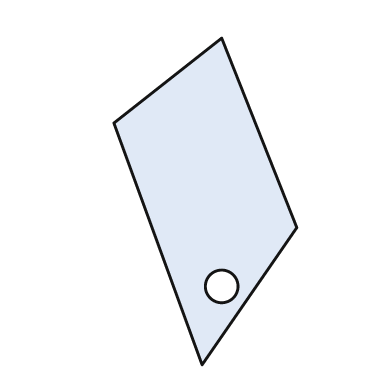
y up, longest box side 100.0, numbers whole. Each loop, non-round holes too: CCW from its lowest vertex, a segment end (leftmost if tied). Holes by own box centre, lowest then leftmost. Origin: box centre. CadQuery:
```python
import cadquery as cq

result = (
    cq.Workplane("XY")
    .moveTo(-1.0, -50.0)
    .lineTo(28.0, -8.0)
    .lineTo(5.0, 50.0)
    .lineTo(-28.0, 24.0)
    .close()
    .moveTo(5.0, -26.0)
    .circle(5.0)
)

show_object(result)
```